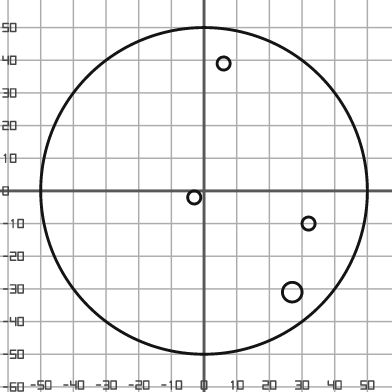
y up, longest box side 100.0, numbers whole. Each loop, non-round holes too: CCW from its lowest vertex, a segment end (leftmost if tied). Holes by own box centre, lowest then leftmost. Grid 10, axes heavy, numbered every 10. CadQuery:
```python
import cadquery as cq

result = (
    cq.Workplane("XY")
    .moveTo(0.0, 0.0)
    .circle(50.0)
    .moveTo(27.0, -31.0)
    .circle(3.0)
    .moveTo(32.0, -10.0)
    .circle(2.0)
    .moveTo(-3.0, -2.0)
    .circle(2.0)
    .moveTo(6.0, 39.0)
    .circle(2.0)
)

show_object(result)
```